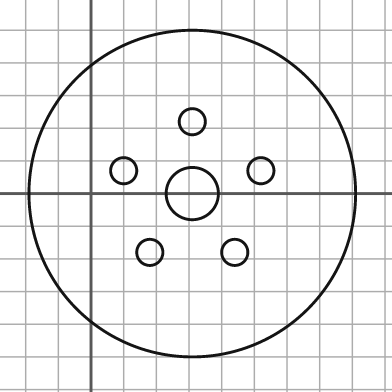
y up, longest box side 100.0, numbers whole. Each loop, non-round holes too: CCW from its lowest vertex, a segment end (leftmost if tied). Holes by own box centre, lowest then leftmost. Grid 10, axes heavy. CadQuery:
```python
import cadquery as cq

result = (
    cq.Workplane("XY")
    .moveTo(31.0, 0.0)
    .circle(50.0)
    .moveTo(18.0, -18.0)
    .circle(4.0)
    .moveTo(44.0, -18.0)
    .circle(4.0)
    .moveTo(31.0, 0.0)
    .circle(8.0)
    .moveTo(10.0, 7.0)
    .circle(4.0)
    .moveTo(52.0, 7.0)
    .circle(4.0)
    .moveTo(31.0, 22.0)
    .circle(4.0)
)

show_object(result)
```